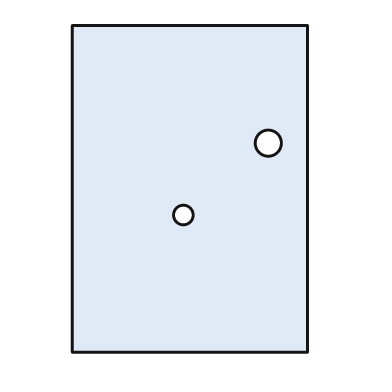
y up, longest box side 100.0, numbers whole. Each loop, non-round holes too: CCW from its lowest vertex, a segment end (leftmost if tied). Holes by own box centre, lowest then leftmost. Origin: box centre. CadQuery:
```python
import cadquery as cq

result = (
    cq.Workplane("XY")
    .moveTo(-36.0, -50.0)
    .lineTo(36.0, -50.0)
    .lineTo(36.0, 50.0)
    .lineTo(-36.0, 50.0)
    .close()
    .moveTo(-2.0, -8.0)
    .circle(3.0)
    .moveTo(24.0, 14.0)
    .circle(4.0)
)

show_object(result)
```